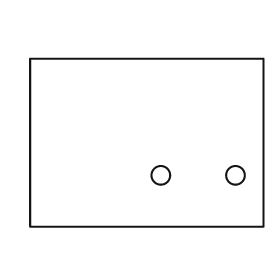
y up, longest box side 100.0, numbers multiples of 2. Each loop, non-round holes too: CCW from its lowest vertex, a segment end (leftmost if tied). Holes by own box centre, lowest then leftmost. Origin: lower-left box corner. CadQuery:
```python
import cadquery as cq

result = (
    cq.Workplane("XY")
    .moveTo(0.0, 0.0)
    .lineTo(100.0, 0.0)
    .lineTo(100.0, 72.0)
    .lineTo(0.0, 72.0)
    .close()
    .moveTo(56.0, 22.0)
    .circle(4.0)
    .moveTo(88.0, 22.0)
    .circle(4.0)
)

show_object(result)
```